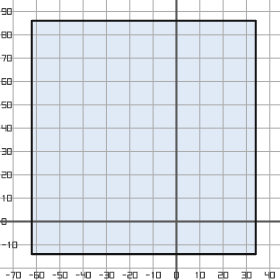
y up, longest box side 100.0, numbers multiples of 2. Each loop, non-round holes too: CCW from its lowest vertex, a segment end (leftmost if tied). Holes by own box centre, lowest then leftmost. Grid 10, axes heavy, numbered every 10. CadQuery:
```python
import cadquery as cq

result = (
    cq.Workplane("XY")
    .moveTo(-62.0, -14.0)
    .lineTo(34.0, -14.0)
    .lineTo(34.0, 86.0)
    .lineTo(-62.0, 86.0)
    .close()
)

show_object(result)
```